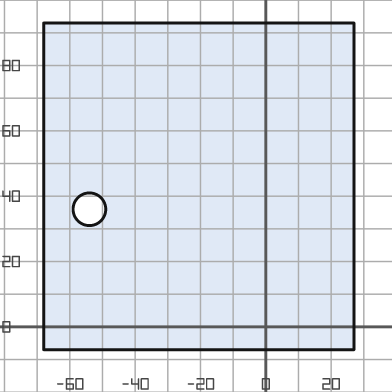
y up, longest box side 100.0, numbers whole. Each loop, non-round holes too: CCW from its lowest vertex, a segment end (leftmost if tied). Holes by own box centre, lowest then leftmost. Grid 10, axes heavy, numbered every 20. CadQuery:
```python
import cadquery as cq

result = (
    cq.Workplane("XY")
    .moveTo(-68.0, -7.0)
    .lineTo(27.0, -7.0)
    .lineTo(27.0, 93.0)
    .lineTo(-68.0, 93.0)
    .close()
    .moveTo(-54.0, 36.0)
    .circle(5.0)
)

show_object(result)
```